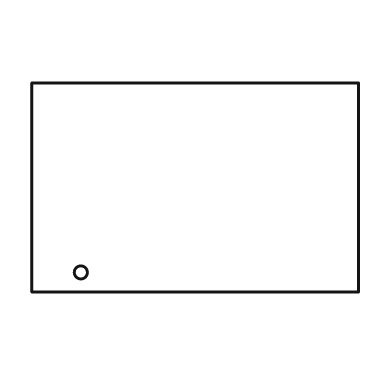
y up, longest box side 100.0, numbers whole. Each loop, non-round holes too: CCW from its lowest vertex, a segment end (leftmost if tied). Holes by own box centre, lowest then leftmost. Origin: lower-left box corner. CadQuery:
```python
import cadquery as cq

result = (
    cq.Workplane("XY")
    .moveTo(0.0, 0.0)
    .lineTo(100.0, 0.0)
    .lineTo(100.0, 64.0)
    .lineTo(0.0, 64.0)
    .close()
    .moveTo(15.0, 6.0)
    .circle(2.0)
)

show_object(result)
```